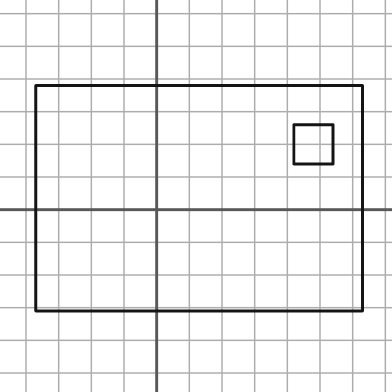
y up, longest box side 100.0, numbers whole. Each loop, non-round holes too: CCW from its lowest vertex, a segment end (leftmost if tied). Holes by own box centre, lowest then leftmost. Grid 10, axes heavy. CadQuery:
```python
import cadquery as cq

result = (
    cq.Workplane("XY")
    .moveTo(-37.0, -31.0)
    .lineTo(63.0, -31.0)
    .lineTo(63.0, 38.0)
    .lineTo(-37.0, 38.0)
    .close()
    .moveTo(42.0, 14.0)
    .lineTo(54.0, 14.0)
    .lineTo(54.0, 26.0)
    .lineTo(42.0, 26.0)
    .close()
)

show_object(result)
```